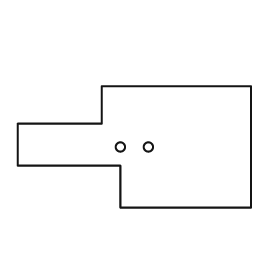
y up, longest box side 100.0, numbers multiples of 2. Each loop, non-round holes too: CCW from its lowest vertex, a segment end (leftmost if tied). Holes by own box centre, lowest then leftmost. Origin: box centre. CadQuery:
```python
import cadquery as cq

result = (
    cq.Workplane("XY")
    .moveTo(-6.0, -26.0)
    .lineTo(50.0, -26.0)
    .lineTo(50.0, 26.0)
    .lineTo(-14.0, 26.0)
    .lineTo(-14.0, 10.0)
    .lineTo(-50.0, 10.0)
    .lineTo(-50.0, -8.0)
    .lineTo(-6.0, -8.0)
    .close()
    .moveTo(-6.0, 0.0)
    .circle(2.0)
    .moveTo(6.0, 0.0)
    .circle(2.0)
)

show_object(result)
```